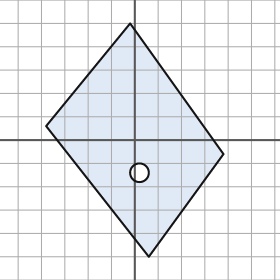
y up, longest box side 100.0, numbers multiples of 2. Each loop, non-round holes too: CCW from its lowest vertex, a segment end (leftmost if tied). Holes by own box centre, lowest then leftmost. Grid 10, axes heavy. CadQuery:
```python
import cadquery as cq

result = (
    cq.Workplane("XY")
    .moveTo(6.0, -50.0)
    .lineTo(38.0, -6.0)
    .lineTo(-2.0, 50.0)
    .lineTo(-38.0, 6.0)
    .close()
    .moveTo(2.0, -14.0)
    .circle(4.0)
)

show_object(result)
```